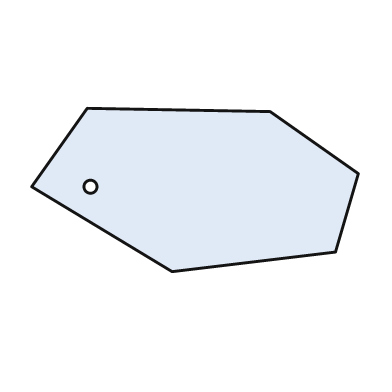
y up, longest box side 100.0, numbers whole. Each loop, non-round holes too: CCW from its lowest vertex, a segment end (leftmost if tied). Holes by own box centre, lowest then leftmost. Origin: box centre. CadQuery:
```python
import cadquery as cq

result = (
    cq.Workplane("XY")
    .moveTo(-7.0, -25.0)
    .lineTo(43.0, -19.0)
    .lineTo(50.0, 5.0)
    .lineTo(23.0, 24.0)
    .lineTo(-33.0, 25.0)
    .lineTo(-50.0, 1.0)
    .close()
    .moveTo(-32.0, 1.0)
    .circle(2.0)
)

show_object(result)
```